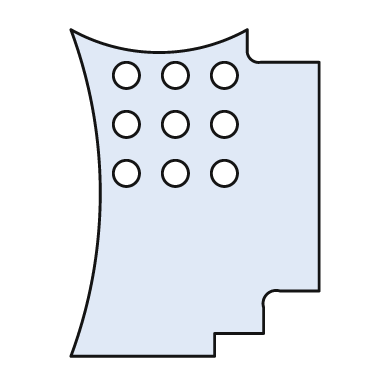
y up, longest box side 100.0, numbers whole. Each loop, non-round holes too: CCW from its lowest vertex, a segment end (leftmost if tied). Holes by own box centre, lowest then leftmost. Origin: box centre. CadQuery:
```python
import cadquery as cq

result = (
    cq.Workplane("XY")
    .moveTo(-38.0, -50.0)
    .lineTo(6.0, -50.0)
    .lineTo(6.0, -43.0)
    .lineTo(21.0, -43.0)
    .lineTo(21.0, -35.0)
    .threePointArc((22.0, -31.0), (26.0, -30.0))
    .lineTo(38.0, -30.0)
    .lineTo(38.0, 40.0)
    .lineTo(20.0, 40.0)
    .threePointArc((17.0, 41.0), (16.0, 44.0))
    .lineTo(16.0, 50.0)
    .threePointArc((-11.0, 43.0), (-38.0, 50.0))
    .threePointArc((-29.0, 0.0), (-38.0, -50.0))
    .close()
    .moveTo(-21.0, 6.0)
    .circle(4.0)
    .moveTo(-6.0, 6.0)
    .circle(4.0)
    .moveTo(9.0, 6.0)
    .circle(4.0)
    .moveTo(-21.0, 21.0)
    .circle(4.0)
    .moveTo(-6.0, 21.0)
    .circle(4.0)
    .moveTo(9.0, 21.0)
    .circle(4.0)
    .moveTo(-21.0, 36.0)
    .circle(4.0)
    .moveTo(-6.0, 36.0)
    .circle(4.0)
    .moveTo(9.0, 36.0)
    .circle(4.0)
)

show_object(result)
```